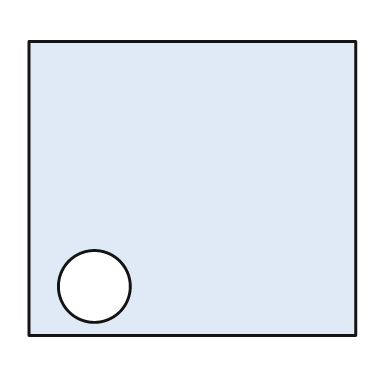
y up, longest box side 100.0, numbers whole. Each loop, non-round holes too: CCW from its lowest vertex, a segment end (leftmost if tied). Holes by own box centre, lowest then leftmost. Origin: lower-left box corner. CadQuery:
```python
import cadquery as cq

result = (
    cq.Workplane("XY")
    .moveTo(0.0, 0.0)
    .lineTo(100.0, 0.0)
    .lineTo(100.0, 90.0)
    .lineTo(0.0, 90.0)
    .close()
    .moveTo(20.0, 15.0)
    .circle(11.0)
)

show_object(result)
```